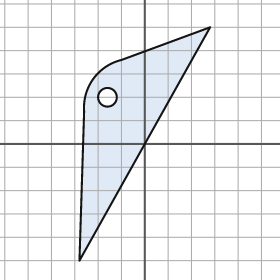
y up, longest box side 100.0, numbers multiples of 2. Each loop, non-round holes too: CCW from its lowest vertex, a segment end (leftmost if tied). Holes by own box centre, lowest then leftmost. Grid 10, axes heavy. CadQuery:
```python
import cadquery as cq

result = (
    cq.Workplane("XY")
    .moveTo(-28.0, -50.0)
    .lineTo(28.0, 50.0)
    .lineTo(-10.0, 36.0)
    .threePointArc((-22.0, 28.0), (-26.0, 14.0))
    .close()
    .moveTo(-16.0, 20.0)
    .circle(4.0)
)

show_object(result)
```